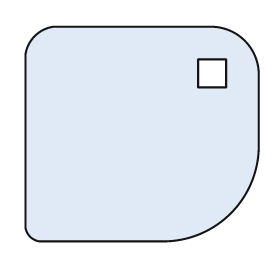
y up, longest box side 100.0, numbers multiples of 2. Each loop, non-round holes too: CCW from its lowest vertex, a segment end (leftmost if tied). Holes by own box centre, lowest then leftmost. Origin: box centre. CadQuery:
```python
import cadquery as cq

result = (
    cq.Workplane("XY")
    .moveTo(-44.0, -46.0)
    .lineTo(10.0, -46.0)
    .threePointArc((38.0, -34.0), (50.0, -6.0))
    .lineTo(50.0, 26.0)
    .threePointArc((44.0, 40.0), (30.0, 46.0))
    .lineTo(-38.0, 46.0)
    .threePointArc((-46.0, 42.0), (-50.0, 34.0))
    .lineTo(-50.0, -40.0)
    .threePointArc((-48.0, -44.0), (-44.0, -46.0))
    .close()
    .moveTo(24.0, 20.0)
    .lineTo(36.0, 20.0)
    .lineTo(36.0, 32.0)
    .lineTo(24.0, 32.0)
    .close()
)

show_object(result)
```